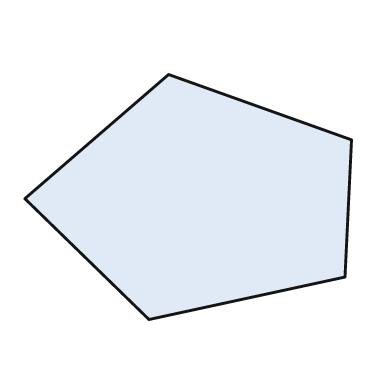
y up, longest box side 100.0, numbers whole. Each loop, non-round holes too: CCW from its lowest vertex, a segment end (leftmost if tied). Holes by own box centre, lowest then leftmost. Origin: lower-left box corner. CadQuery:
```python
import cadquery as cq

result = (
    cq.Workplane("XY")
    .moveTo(38.0, 0.0)
    .lineTo(98.0, 13.0)
    .lineTo(100.0, 55.0)
    .lineTo(44.0, 75.0)
    .lineTo(0.0, 37.0)
    .close()
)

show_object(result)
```